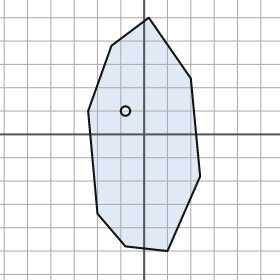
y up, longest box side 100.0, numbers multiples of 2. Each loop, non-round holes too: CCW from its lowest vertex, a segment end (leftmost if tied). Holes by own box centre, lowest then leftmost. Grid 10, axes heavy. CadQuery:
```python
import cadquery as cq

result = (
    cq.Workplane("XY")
    .moveTo(10.0, -50.0)
    .lineTo(24.0, -18.0)
    .lineTo(20.0, 24.0)
    .lineTo(2.0, 50.0)
    .lineTo(-14.0, 38.0)
    .lineTo(-24.0, 10.0)
    .lineTo(-20.0, -34.0)
    .lineTo(-8.0, -48.0)
    .close()
    .moveTo(-8.0, 10.0)
    .circle(2.0)
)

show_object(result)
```